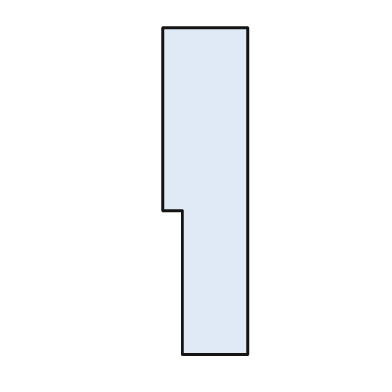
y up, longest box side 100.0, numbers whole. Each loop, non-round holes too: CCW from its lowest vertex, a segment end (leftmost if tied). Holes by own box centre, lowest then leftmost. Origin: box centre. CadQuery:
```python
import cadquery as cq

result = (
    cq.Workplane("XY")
    .moveTo(-7.0, -50.0)
    .lineTo(13.0, -50.0)
    .lineTo(13.0, 50.0)
    .lineTo(-13.0, 50.0)
    .lineTo(-13.0, -6.0)
    .lineTo(-7.0, -6.0)
    .close()
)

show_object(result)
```